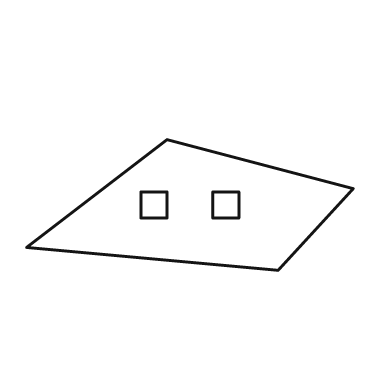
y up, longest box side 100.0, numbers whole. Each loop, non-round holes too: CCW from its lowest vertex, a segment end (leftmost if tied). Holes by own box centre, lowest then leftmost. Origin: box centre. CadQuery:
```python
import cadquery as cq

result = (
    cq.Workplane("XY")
    .moveTo(27.0, -20.0)
    .lineTo(50.0, 5.0)
    .lineTo(-7.0, 20.0)
    .lineTo(-50.0, -13.0)
    .close()
    .moveTo(-15.0, -4.0)
    .lineTo(-7.0, -4.0)
    .lineTo(-7.0, 4.0)
    .lineTo(-15.0, 4.0)
    .close()
    .moveTo(7.0, -4.0)
    .lineTo(15.0, -4.0)
    .lineTo(15.0, 4.0)
    .lineTo(7.0, 4.0)
    .close()
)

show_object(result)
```